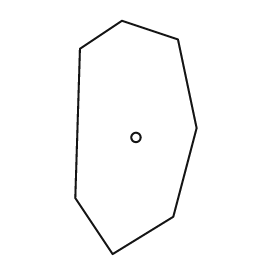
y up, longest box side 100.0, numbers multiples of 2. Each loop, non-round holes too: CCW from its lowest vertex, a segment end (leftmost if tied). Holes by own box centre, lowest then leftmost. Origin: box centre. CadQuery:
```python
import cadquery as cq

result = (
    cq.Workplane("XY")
    .moveTo(-10.0, -50.0)
    .lineTo(16.0, -34.0)
    .lineTo(26.0, 4.0)
    .lineTo(18.0, 42.0)
    .lineTo(-6.0, 50.0)
    .lineTo(-24.0, 38.0)
    .lineTo(-26.0, -26.0)
    .close()
    .moveTo(0.0, 0.0)
    .circle(2.0)
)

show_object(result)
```